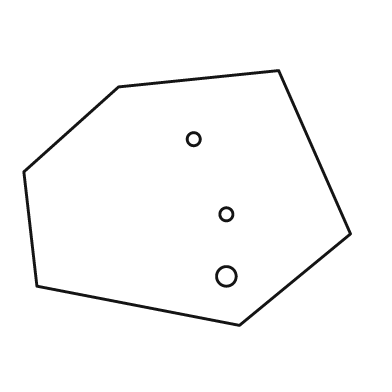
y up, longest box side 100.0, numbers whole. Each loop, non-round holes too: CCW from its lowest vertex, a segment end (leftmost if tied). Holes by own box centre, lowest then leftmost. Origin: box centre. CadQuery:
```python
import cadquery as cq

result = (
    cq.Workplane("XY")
    .moveTo(16.0, -39.0)
    .lineTo(50.0, -11.0)
    .lineTo(28.0, 39.0)
    .lineTo(-21.0, 34.0)
    .lineTo(-50.0, 8.0)
    .lineTo(-46.0, -27.0)
    .close()
    .moveTo(12.0, -24.0)
    .circle(3.0)
    .moveTo(12.0, -5.0)
    .circle(2.0)
    .moveTo(2.0, 18.0)
    .circle(2.0)
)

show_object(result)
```